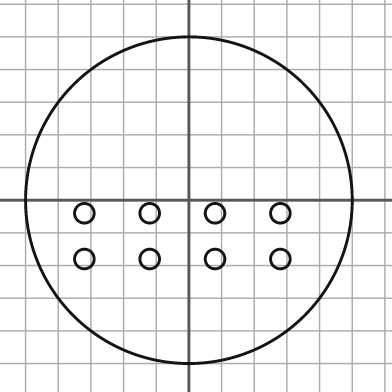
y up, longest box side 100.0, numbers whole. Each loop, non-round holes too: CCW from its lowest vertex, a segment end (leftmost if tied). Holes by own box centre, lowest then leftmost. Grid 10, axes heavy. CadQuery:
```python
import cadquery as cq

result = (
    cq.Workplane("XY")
    .moveTo(0.0, 0.0)
    .circle(50.0)
    .moveTo(-32.0, -18.0)
    .circle(3.0)
    .moveTo(-12.0, -18.0)
    .circle(3.0)
    .moveTo(8.0, -18.0)
    .circle(3.0)
    .moveTo(28.0, -18.0)
    .circle(3.0)
    .moveTo(-32.0, -4.0)
    .circle(3.0)
    .moveTo(-12.0, -4.0)
    .circle(3.0)
    .moveTo(8.0, -4.0)
    .circle(3.0)
    .moveTo(28.0, -4.0)
    .circle(3.0)
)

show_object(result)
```